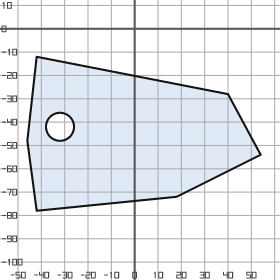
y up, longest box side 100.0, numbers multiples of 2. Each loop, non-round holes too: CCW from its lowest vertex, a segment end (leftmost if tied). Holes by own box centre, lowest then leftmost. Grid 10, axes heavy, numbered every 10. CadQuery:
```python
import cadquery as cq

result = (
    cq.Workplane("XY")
    .moveTo(-42.0, -78.0)
    .lineTo(18.0, -72.0)
    .lineTo(54.0, -54.0)
    .lineTo(40.0, -28.0)
    .lineTo(-42.0, -12.0)
    .lineTo(-46.0, -48.0)
    .close()
    .moveTo(-32.0, -42.0)
    .circle(6.0)
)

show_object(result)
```